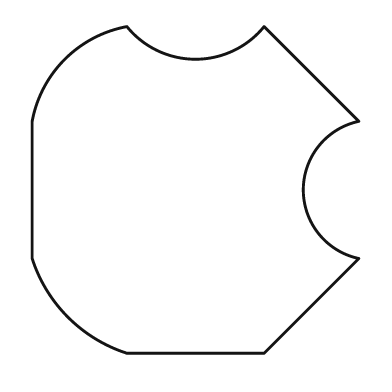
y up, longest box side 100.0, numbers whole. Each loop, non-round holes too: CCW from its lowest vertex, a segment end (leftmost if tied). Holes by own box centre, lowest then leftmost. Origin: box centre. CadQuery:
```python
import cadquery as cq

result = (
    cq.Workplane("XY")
    .moveTo(-21.0, -50.0)
    .lineTo(21.0, -50.0)
    .lineTo(50.0, -21.0)
    .threePointArc((33.0, 0.0), (50.0, 21.0))
    .lineTo(21.0, 50.0)
    .threePointArc((0.0, 40.0), (-21.0, 50.0))
    .threePointArc((-40.0, 40.0), (-50.0, 21.0))
    .lineTo(-50.0, -21.0)
    .threePointArc((-39.0, -39.0), (-21.0, -50.0))
    .close()
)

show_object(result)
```